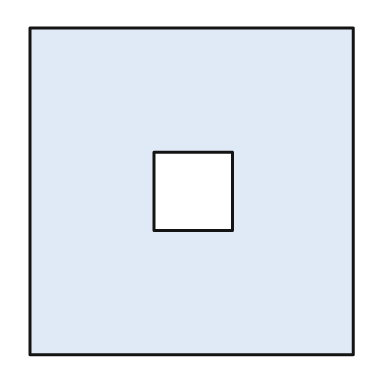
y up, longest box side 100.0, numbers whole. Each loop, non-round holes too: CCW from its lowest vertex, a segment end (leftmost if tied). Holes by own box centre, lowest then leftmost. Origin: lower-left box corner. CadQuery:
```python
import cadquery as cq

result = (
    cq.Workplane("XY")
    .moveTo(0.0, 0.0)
    .lineTo(99.0, 0.0)
    .lineTo(99.0, 100.0)
    .lineTo(0.0, 100.0)
    .close()
    .moveTo(38.0, 38.0)
    .lineTo(62.0, 38.0)
    .lineTo(62.0, 62.0)
    .lineTo(38.0, 62.0)
    .close()
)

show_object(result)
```